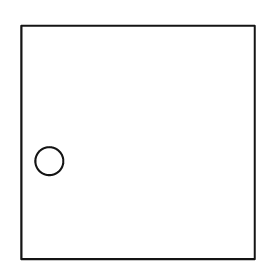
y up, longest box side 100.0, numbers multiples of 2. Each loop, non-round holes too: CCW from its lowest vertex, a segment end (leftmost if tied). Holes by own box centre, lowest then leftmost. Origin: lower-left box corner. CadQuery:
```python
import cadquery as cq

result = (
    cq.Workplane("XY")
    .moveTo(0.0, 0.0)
    .lineTo(100.0, 0.0)
    .lineTo(100.0, 100.0)
    .lineTo(0.0, 100.0)
    .close()
    .moveTo(12.0, 42.0)
    .circle(6.0)
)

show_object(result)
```